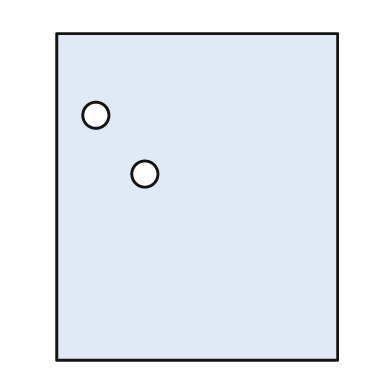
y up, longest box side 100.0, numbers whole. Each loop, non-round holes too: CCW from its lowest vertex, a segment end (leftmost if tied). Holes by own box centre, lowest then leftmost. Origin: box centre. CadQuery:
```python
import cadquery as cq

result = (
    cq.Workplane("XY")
    .moveTo(-43.0, -50.0)
    .lineTo(43.0, -50.0)
    .lineTo(43.0, 50.0)
    .lineTo(-43.0, 50.0)
    .close()
    .moveTo(-16.0, 7.0)
    .circle(4.0)
    .moveTo(-31.0, 25.0)
    .circle(4.0)
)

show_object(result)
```